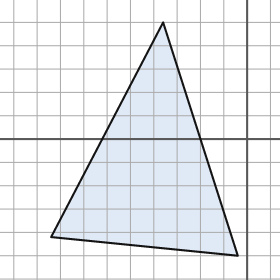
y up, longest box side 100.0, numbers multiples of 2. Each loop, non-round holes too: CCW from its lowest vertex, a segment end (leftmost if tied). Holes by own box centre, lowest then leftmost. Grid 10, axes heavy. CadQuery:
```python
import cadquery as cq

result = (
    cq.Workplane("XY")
    .moveTo(-4.0, -50.0)
    .lineTo(-36.0, 50.0)
    .lineTo(-84.0, -42.0)
    .close()
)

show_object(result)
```